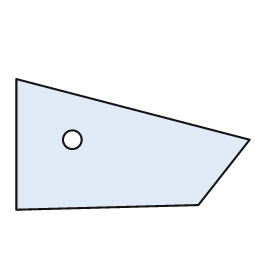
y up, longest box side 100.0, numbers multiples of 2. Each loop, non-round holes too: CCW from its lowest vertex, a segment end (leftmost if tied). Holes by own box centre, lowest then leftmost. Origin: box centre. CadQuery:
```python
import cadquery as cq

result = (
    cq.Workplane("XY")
    .moveTo(-50.0, -28.0)
    .lineTo(28.0, -26.0)
    .lineTo(50.0, 2.0)
    .lineTo(-50.0, 28.0)
    .close()
    .moveTo(-26.0, 2.0)
    .circle(4.0)
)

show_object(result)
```